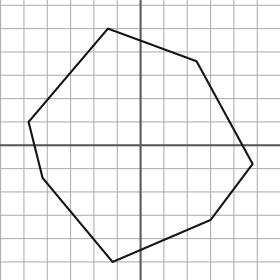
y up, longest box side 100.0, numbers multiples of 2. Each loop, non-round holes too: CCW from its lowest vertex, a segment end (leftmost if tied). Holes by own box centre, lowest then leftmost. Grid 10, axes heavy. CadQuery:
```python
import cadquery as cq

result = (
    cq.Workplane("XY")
    .moveTo(-12.0, -50.0)
    .lineTo(30.0, -32.0)
    .lineTo(48.0, -8.0)
    .lineTo(24.0, 36.0)
    .lineTo(-14.0, 50.0)
    .lineTo(-48.0, 10.0)
    .lineTo(-42.0, -14.0)
    .close()
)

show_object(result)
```